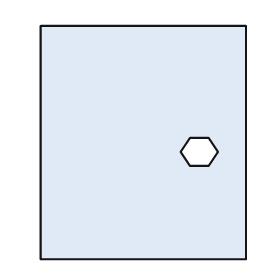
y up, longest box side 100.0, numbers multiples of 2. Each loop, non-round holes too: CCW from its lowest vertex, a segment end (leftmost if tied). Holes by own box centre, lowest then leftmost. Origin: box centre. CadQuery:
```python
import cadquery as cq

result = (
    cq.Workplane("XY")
    .moveTo(-44.0, -50.0)
    .lineTo(44.0, -50.0)
    .lineTo(44.0, 50.0)
    .lineTo(-44.0, 50.0)
    .close()
    .moveTo(20.0, -10.0)
    .lineTo(28.0, -10.0)
    .lineTo(32.0, -4.0)
    .lineTo(28.0, 2.0)
    .lineTo(20.0, 2.0)
    .lineTo(16.0, -4.0)
    .close()
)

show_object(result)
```